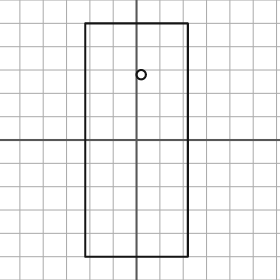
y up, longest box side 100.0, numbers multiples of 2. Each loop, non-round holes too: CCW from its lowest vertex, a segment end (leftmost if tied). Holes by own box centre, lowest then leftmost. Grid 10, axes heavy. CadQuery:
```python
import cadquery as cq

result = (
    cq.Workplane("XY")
    .moveTo(-22.0, -50.0)
    .lineTo(22.0, -50.0)
    .lineTo(22.0, 50.0)
    .lineTo(-22.0, 50.0)
    .close()
    .moveTo(2.0, 28.0)
    .circle(2.0)
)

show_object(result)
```